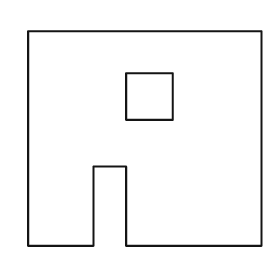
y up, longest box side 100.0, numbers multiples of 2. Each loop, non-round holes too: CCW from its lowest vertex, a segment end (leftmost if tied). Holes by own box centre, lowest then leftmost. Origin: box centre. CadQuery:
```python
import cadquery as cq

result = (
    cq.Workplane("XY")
    .moveTo(-50.0, -46.0)
    .lineTo(-22.0, -46.0)
    .lineTo(-22.0, -12.0)
    .lineTo(-8.0, -12.0)
    .lineTo(-8.0, -46.0)
    .lineTo(50.0, -46.0)
    .lineTo(50.0, 46.0)
    .lineTo(-50.0, 46.0)
    .close()
    .moveTo(-8.0, 8.0)
    .lineTo(12.0, 8.0)
    .lineTo(12.0, 28.0)
    .lineTo(-8.0, 28.0)
    .close()
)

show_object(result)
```